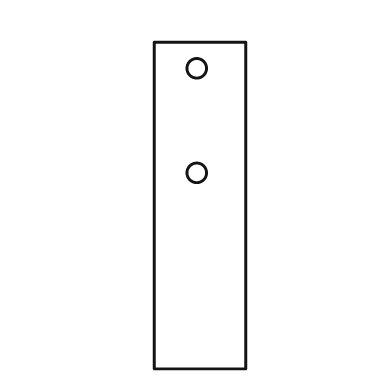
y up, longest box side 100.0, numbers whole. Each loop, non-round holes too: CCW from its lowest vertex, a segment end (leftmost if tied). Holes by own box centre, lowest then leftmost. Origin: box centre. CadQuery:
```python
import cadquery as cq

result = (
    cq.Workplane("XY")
    .moveTo(-14.0, -50.0)
    .lineTo(14.0, -50.0)
    .lineTo(14.0, 50.0)
    .lineTo(-14.0, 50.0)
    .close()
    .moveTo(-1.0, 10.0)
    .circle(3.0)
    .moveTo(-1.0, 42.0)
    .circle(3.0)
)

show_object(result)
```